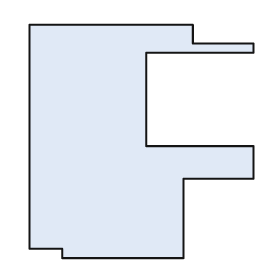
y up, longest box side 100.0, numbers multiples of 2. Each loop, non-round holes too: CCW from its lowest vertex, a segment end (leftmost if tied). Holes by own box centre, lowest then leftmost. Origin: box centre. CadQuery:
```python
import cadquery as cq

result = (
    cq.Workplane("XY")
    .moveTo(-34.0, -50.0)
    .lineTo(18.0, -50.0)
    .lineTo(18.0, -16.0)
    .lineTo(48.0, -16.0)
    .lineTo(48.0, -2.0)
    .lineTo(2.0, -2.0)
    .lineTo(2.0, 38.0)
    .lineTo(48.0, 38.0)
    .lineTo(48.0, 42.0)
    .lineTo(22.0, 42.0)
    .lineTo(22.0, 50.0)
    .lineTo(-48.0, 50.0)
    .lineTo(-48.0, -46.0)
    .lineTo(-34.0, -46.0)
    .close()
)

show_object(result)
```